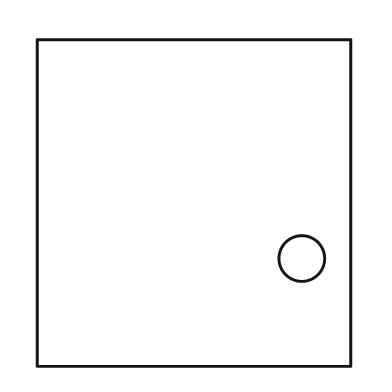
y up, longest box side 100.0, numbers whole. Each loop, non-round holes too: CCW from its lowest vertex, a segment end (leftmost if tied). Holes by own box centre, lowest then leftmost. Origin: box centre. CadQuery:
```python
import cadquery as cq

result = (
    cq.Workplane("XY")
    .moveTo(-48.0, -50.0)
    .lineTo(48.0, -50.0)
    .lineTo(48.0, 50.0)
    .lineTo(-48.0, 50.0)
    .close()
    .moveTo(33.0, -17.0)
    .circle(7.0)
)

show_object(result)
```